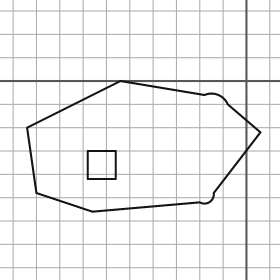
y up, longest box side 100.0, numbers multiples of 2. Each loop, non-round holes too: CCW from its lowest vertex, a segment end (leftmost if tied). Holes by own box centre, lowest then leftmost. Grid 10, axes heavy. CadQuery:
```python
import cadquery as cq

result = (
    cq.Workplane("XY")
    .moveTo(-66.0, -56.0)
    .lineTo(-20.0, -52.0)
    .threePointArc((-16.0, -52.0), (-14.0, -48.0))
    .lineTo(6.0, -22.0)
    .lineTo(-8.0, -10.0)
    .threePointArc((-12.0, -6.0), (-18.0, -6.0))
    .lineTo(-54.0, 0.0)
    .lineTo(-94.0, -20.0)
    .lineTo(-90.0, -48.0)
    .close()
    .moveTo(-68.0, -42.0)
    .lineTo(-56.0, -42.0)
    .lineTo(-56.0, -30.0)
    .lineTo(-68.0, -30.0)
    .close()
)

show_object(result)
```